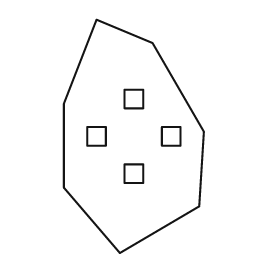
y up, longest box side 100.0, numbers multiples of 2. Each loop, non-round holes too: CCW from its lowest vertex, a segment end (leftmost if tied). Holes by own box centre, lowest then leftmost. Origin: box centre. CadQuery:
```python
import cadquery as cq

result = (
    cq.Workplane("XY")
    .moveTo(-6.0, -50.0)
    .lineTo(28.0, -30.0)
    .lineTo(30.0, 2.0)
    .lineTo(8.0, 40.0)
    .lineTo(-16.0, 50.0)
    .lineTo(-30.0, 14.0)
    .lineTo(-30.0, -22.0)
    .close()
    .moveTo(-4.0, -20.0)
    .lineTo(4.0, -20.0)
    .lineTo(4.0, -12.0)
    .lineTo(-4.0, -12.0)
    .close()
    .moveTo(-20.0, -4.0)
    .lineTo(-12.0, -4.0)
    .lineTo(-12.0, 4.0)
    .lineTo(-20.0, 4.0)
    .close()
    .moveTo(12.0, -4.0)
    .lineTo(20.0, -4.0)
    .lineTo(20.0, 4.0)
    .lineTo(12.0, 4.0)
    .close()
    .moveTo(-4.0, 12.0)
    .lineTo(4.0, 12.0)
    .lineTo(4.0, 20.0)
    .lineTo(-4.0, 20.0)
    .close()
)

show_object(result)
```